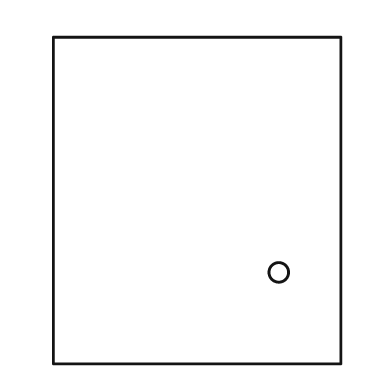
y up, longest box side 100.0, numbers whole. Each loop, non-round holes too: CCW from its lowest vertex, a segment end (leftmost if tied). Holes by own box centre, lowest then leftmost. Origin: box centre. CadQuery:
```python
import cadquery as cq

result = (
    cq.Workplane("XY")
    .moveTo(-44.0, -50.0)
    .lineTo(44.0, -50.0)
    .lineTo(44.0, 50.0)
    .lineTo(-44.0, 50.0)
    .close()
    .moveTo(25.0, -22.0)
    .circle(3.0)
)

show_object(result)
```